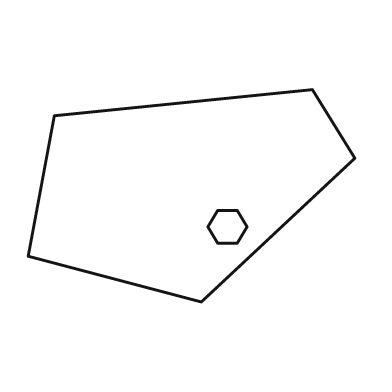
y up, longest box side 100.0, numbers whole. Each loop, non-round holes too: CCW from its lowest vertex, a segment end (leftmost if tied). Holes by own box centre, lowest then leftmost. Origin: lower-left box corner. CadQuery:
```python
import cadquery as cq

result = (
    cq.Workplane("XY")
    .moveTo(53.0, 0.0)
    .lineTo(100.0, 44.0)
    .lineTo(87.0, 65.0)
    .lineTo(8.0, 57.0)
    .lineTo(0.0, 14.0)
    .close()
    .moveTo(58.0, 18.0)
    .lineTo(64.0, 18.0)
    .lineTo(67.0, 23.0)
    .lineTo(64.0, 28.0)
    .lineTo(58.0, 28.0)
    .lineTo(55.0, 23.0)
    .close()
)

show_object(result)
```